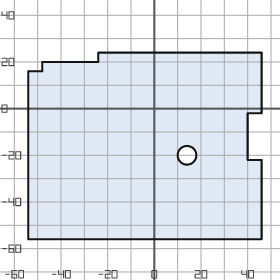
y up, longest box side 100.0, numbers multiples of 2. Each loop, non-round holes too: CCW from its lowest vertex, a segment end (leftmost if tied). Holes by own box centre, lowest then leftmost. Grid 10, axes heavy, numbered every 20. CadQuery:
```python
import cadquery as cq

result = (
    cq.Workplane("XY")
    .moveTo(-54.0, -56.0)
    .lineTo(46.0, -56.0)
    .lineTo(46.0, -22.0)
    .lineTo(40.0, -22.0)
    .lineTo(40.0, -2.0)
    .lineTo(46.0, -2.0)
    .lineTo(46.0, 24.0)
    .lineTo(-24.0, 24.0)
    .lineTo(-24.0, 20.0)
    .lineTo(-48.0, 20.0)
    .lineTo(-48.0, 16.0)
    .lineTo(-54.0, 16.0)
    .close()
    .moveTo(14.0, -20.0)
    .circle(4.0)
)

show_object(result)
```